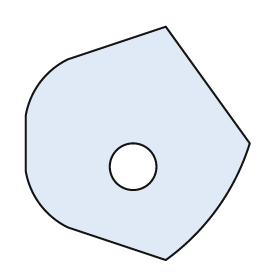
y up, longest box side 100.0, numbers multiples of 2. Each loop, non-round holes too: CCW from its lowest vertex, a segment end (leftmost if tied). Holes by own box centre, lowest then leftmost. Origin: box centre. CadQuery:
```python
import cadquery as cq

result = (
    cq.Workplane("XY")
    .moveTo(12.0, -50.0)
    .threePointArc((34.0, -28.0), (48.0, 0.0))
    .lineTo(12.0, 50.0)
    .lineTo(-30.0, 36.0)
    .threePointArc((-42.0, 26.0), (-48.0, 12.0))
    .lineTo(-48.0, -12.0)
    .threePointArc((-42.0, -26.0), (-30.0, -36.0))
    .close()
    .moveTo(-2.0, -10.0)
    .circle(10.0)
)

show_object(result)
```